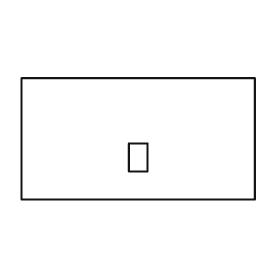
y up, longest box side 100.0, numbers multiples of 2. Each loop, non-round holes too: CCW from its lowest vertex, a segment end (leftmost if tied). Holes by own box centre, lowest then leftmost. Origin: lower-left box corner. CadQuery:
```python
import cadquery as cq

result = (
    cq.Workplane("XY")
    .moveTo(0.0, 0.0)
    .lineTo(100.0, 0.0)
    .lineTo(100.0, 52.0)
    .lineTo(0.0, 52.0)
    .close()
    .moveTo(46.0, 12.0)
    .lineTo(54.0, 12.0)
    .lineTo(54.0, 24.0)
    .lineTo(46.0, 24.0)
    .close()
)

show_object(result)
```